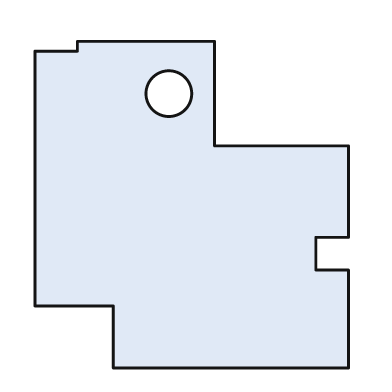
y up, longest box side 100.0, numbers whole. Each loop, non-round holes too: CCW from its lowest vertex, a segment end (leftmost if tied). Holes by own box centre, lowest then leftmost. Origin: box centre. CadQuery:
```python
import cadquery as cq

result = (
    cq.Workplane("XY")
    .moveTo(-24.0, -50.0)
    .lineTo(48.0, -50.0)
    .lineTo(48.0, -20.0)
    .lineTo(38.0, -20.0)
    .lineTo(38.0, -10.0)
    .lineTo(48.0, -10.0)
    .lineTo(48.0, 18.0)
    .lineTo(7.0, 18.0)
    .lineTo(7.0, 50.0)
    .lineTo(-35.0, 50.0)
    .lineTo(-35.0, 47.0)
    .lineTo(-48.0, 47.0)
    .lineTo(-48.0, -31.0)
    .lineTo(-24.0, -31.0)
    .close()
    .moveTo(-7.0, 34.0)
    .circle(7.0)
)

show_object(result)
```